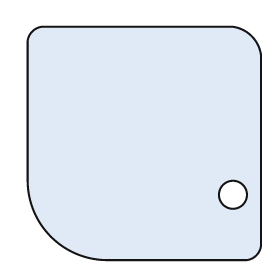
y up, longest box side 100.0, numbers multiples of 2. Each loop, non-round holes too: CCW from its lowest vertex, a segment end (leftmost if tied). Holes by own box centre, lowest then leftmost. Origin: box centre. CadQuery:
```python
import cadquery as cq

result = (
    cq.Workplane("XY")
    .moveTo(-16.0, -50.0)
    .lineTo(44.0, -50.0)
    .threePointArc((48.0, -48.0), (50.0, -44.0))
    .lineTo(50.0, 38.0)
    .threePointArc((46.0, 46.0), (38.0, 50.0))
    .lineTo(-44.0, 50.0)
    .threePointArc((-48.0, 48.0), (-50.0, 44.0))
    .lineTo(-50.0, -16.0)
    .threePointArc((-40.0, -40.0), (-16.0, -50.0))
    .close()
    .moveTo(38.0, -22.0)
    .circle(6.0)
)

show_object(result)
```